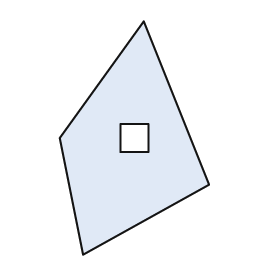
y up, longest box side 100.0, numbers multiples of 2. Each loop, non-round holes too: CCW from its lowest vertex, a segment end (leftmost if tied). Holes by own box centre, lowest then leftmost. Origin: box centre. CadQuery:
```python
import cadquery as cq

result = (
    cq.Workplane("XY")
    .moveTo(-22.0, -50.0)
    .lineTo(32.0, -20.0)
    .lineTo(4.0, 50.0)
    .lineTo(-32.0, 0.0)
    .close()
    .moveTo(-6.0, -6.0)
    .lineTo(6.0, -6.0)
    .lineTo(6.0, 6.0)
    .lineTo(-6.0, 6.0)
    .close()
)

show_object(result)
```